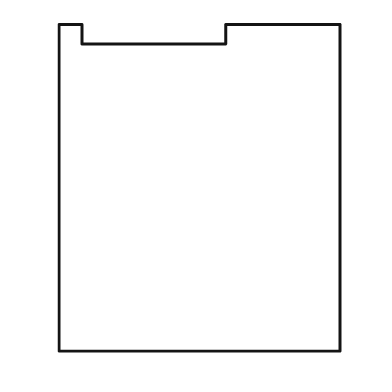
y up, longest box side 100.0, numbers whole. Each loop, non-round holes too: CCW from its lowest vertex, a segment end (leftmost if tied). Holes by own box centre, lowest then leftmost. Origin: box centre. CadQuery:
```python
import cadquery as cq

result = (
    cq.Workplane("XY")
    .moveTo(-43.0, -50.0)
    .lineTo(43.0, -50.0)
    .lineTo(43.0, 50.0)
    .lineTo(8.0, 50.0)
    .lineTo(8.0, 44.0)
    .lineTo(-36.0, 44.0)
    .lineTo(-36.0, 50.0)
    .lineTo(-43.0, 50.0)
    .close()
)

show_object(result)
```